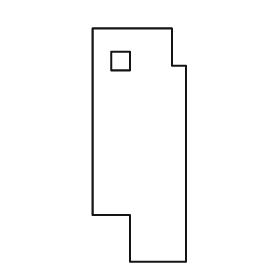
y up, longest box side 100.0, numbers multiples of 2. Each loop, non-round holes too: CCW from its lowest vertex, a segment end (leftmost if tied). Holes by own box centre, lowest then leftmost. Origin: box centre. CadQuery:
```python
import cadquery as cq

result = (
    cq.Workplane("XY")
    .moveTo(-4.0, -50.0)
    .lineTo(20.0, -50.0)
    .lineTo(20.0, 34.0)
    .lineTo(14.0, 34.0)
    .lineTo(14.0, 50.0)
    .lineTo(-20.0, 50.0)
    .lineTo(-20.0, -30.0)
    .lineTo(-4.0, -30.0)
    .close()
    .moveTo(-12.0, 32.0)
    .lineTo(-4.0, 32.0)
    .lineTo(-4.0, 40.0)
    .lineTo(-12.0, 40.0)
    .close()
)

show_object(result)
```